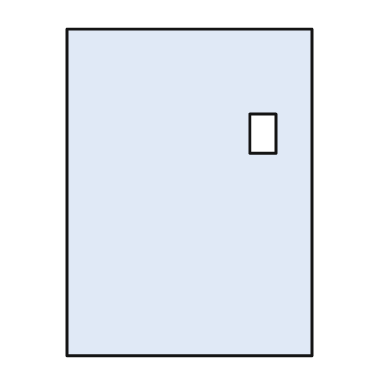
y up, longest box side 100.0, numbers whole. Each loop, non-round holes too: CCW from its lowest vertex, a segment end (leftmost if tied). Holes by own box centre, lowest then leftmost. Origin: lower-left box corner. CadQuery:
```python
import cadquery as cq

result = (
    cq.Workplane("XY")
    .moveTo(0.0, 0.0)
    .lineTo(75.0, 0.0)
    .lineTo(75.0, 100.0)
    .lineTo(0.0, 100.0)
    .close()
    .moveTo(56.0, 62.0)
    .lineTo(64.0, 62.0)
    .lineTo(64.0, 74.0)
    .lineTo(56.0, 74.0)
    .close()
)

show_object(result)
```